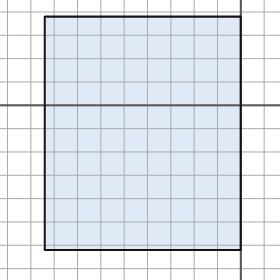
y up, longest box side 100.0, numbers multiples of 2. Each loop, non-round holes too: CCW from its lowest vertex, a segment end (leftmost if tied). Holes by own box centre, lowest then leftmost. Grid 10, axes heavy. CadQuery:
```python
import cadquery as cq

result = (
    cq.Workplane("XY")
    .moveTo(-84.0, -62.0)
    .lineTo(0.0, -62.0)
    .lineTo(0.0, 38.0)
    .lineTo(-84.0, 38.0)
    .close()
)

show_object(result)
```